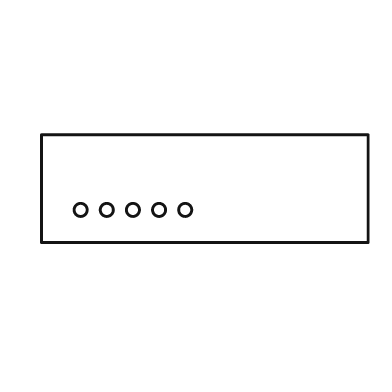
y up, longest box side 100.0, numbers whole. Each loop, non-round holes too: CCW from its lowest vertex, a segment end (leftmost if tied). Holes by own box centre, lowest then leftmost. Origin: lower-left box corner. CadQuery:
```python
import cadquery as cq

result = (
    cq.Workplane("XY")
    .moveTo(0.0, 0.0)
    .lineTo(100.0, 0.0)
    .lineTo(100.0, 33.0)
    .lineTo(0.0, 33.0)
    .close()
    .moveTo(12.0, 10.0)
    .circle(2.0)
    .moveTo(20.0, 10.0)
    .circle(2.0)
    .moveTo(28.0, 10.0)
    .circle(2.0)
    .moveTo(36.0, 10.0)
    .circle(2.0)
    .moveTo(44.0, 10.0)
    .circle(2.0)
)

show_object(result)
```